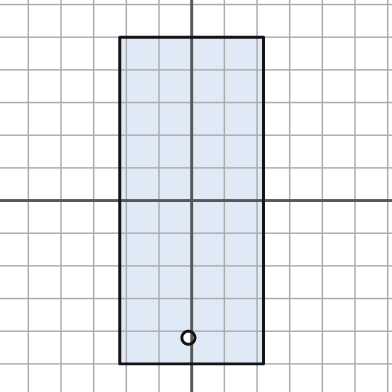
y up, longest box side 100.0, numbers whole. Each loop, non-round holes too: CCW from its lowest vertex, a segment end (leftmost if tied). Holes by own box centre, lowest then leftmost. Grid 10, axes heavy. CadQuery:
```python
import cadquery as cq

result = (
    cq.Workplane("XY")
    .moveTo(-22.0, -50.0)
    .lineTo(22.0, -50.0)
    .lineTo(22.0, 50.0)
    .lineTo(-22.0, 50.0)
    .close()
    .moveTo(-1.0, -42.0)
    .circle(2.0)
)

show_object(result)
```